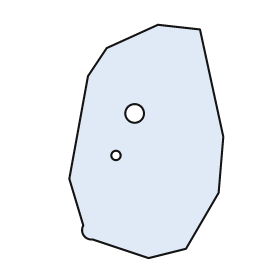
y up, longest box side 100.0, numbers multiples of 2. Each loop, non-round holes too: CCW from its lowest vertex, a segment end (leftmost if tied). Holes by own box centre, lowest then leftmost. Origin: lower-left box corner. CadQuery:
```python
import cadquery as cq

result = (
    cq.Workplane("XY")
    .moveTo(34.0, 0.0)
    .lineTo(50.0, 4.0)
    .lineTo(64.0, 28.0)
    .lineTo(66.0, 52.0)
    .lineTo(56.0, 98.0)
    .lineTo(38.0, 100.0)
    .lineTo(16.0, 90.0)
    .lineTo(8.0, 78.0)
    .lineTo(0.0, 34.0)
    .lineTo(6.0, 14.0)
    .threePointArc((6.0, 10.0), (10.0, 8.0))
    .close()
    .moveTo(20.0, 44.0)
    .circle(2.0)
    .moveTo(28.0, 62.0)
    .circle(4.0)
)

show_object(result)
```